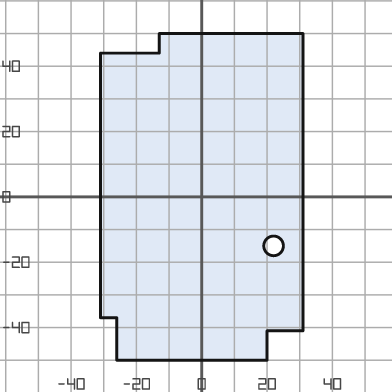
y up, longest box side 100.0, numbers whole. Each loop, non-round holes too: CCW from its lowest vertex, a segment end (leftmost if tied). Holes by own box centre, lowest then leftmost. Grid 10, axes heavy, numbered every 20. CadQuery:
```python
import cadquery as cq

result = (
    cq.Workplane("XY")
    .moveTo(-26.0, -50.0)
    .lineTo(20.0, -50.0)
    .lineTo(20.0, -41.0)
    .lineTo(31.0, -41.0)
    .lineTo(31.0, 50.0)
    .lineTo(-13.0, 50.0)
    .lineTo(-13.0, 44.0)
    .lineTo(-31.0, 44.0)
    .lineTo(-31.0, -37.0)
    .lineTo(-26.0, -37.0)
    .close()
    .moveTo(22.0, -15.0)
    .circle(3.0)
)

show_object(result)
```